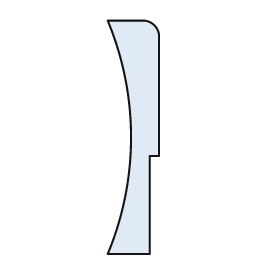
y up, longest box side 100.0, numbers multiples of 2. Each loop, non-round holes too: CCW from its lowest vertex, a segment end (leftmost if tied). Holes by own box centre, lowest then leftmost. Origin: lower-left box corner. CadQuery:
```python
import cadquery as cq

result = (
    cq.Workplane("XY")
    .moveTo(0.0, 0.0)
    .lineTo(18.0, 0.0)
    .lineTo(18.0, 42.0)
    .lineTo(22.0, 42.0)
    .lineTo(22.0, 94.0)
    .threePointArc((20.0, 98.0), (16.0, 100.0))
    .lineTo(0.0, 100.0)
    .threePointArc((10.0, 50.0), (0.0, 0.0))
    .close()
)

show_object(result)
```